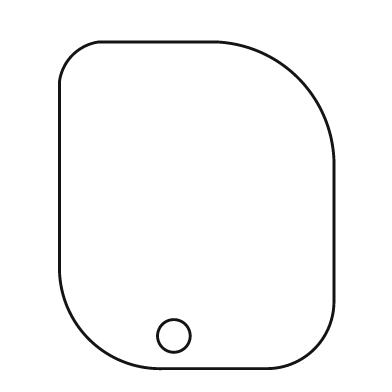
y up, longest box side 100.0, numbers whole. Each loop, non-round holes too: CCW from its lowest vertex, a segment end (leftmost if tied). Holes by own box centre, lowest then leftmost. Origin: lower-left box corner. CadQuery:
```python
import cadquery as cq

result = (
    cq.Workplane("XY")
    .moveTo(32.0, 0.0)
    .lineTo(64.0, 0.0)
    .threePointArc((78.0, 6.0), (84.0, 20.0))
    .lineTo(84.0, 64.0)
    .threePointArc((73.0, 89.0), (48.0, 100.0))
    .lineTo(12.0, 100.0)
    .threePointArc((4.0, 96.0), (0.0, 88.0))
    .lineTo(0.0, 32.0)
    .threePointArc((9.0, 9.0), (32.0, 0.0))
    .close()
    .moveTo(35.0, 10.0)
    .circle(5.0)
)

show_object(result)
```